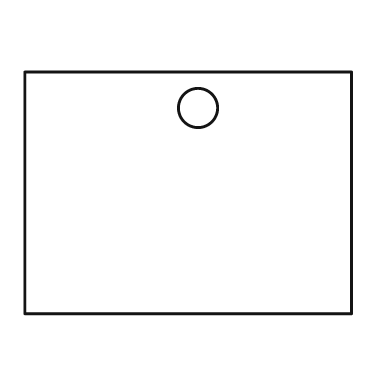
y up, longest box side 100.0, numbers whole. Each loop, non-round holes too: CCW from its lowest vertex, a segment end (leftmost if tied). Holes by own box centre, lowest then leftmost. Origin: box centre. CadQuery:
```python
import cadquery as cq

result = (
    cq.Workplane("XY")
    .moveTo(-50.0, -37.0)
    .lineTo(50.0, -37.0)
    .lineTo(50.0, 37.0)
    .lineTo(-50.0, 37.0)
    .close()
    .moveTo(3.0, 26.0)
    .circle(6.0)
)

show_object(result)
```